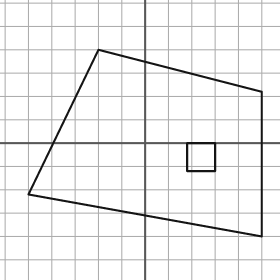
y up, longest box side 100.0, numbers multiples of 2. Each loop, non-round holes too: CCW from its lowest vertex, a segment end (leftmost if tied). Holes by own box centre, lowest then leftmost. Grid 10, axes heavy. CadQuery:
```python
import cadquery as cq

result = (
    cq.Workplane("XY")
    .moveTo(50.0, -40.0)
    .lineTo(50.0, 22.0)
    .lineTo(-20.0, 40.0)
    .lineTo(-50.0, -22.0)
    .close()
    .moveTo(18.0, -12.0)
    .lineTo(30.0, -12.0)
    .lineTo(30.0, 0.0)
    .lineTo(18.0, 0.0)
    .close()
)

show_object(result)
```